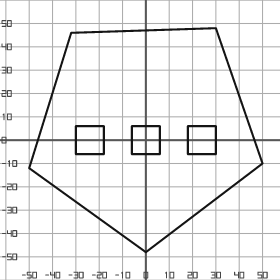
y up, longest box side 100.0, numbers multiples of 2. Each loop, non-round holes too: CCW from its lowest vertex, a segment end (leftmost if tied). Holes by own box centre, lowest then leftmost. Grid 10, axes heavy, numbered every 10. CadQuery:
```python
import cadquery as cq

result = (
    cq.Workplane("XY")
    .moveTo(0.0, -48.0)
    .lineTo(50.0, -10.0)
    .lineTo(30.0, 48.0)
    .lineTo(-32.0, 46.0)
    .lineTo(-50.0, -12.0)
    .close()
    .moveTo(-30.0, -6.0)
    .lineTo(-18.0, -6.0)
    .lineTo(-18.0, 6.0)
    .lineTo(-30.0, 6.0)
    .close()
    .moveTo(-6.0, -6.0)
    .lineTo(6.0, -6.0)
    .lineTo(6.0, 6.0)
    .lineTo(-6.0, 6.0)
    .close()
    .moveTo(18.0, -6.0)
    .lineTo(30.0, -6.0)
    .lineTo(30.0, 6.0)
    .lineTo(18.0, 6.0)
    .close()
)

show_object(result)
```